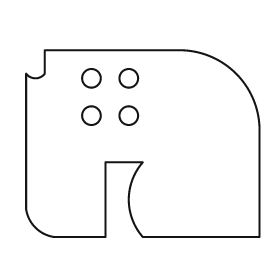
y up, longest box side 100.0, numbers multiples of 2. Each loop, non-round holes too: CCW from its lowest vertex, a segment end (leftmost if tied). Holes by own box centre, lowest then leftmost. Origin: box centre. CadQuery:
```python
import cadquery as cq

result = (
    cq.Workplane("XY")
    .moveTo(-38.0, -40.0)
    .lineTo(-16.0, -40.0)
    .lineTo(-16.0, -8.0)
    .lineTo(0.0, -8.0)
    .threePointArc((-6.0, -24.0), (0.0, -40.0))
    .lineTo(50.0, -40.0)
    .lineTo(50.0, 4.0)
    .threePointArc((40.0, 30.0), (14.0, 40.0))
    .lineTo(-42.0, 40.0)
    .lineTo(-42.0, 30.0)
    .threePointArc((-46.0, 28.0), (-50.0, 30.0))
    .lineTo(-50.0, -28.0)
    .threePointArc((-46.0, -36.0), (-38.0, -40.0))
    .close()
    .moveTo(-22.0, 12.0)
    .circle(4.0)
    .moveTo(-6.0, 12.0)
    .circle(4.0)
    .moveTo(-22.0, 28.0)
    .circle(4.0)
    .moveTo(-6.0, 28.0)
    .circle(4.0)
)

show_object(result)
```